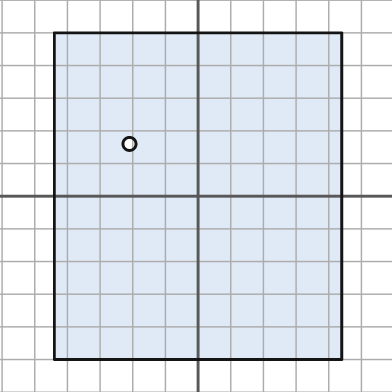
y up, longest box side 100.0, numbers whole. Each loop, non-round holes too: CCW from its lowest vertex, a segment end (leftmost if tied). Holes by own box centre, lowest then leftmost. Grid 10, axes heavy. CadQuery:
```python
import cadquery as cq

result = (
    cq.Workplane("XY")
    .moveTo(-44.0, -50.0)
    .lineTo(44.0, -50.0)
    .lineTo(44.0, 50.0)
    .lineTo(-44.0, 50.0)
    .close()
    .moveTo(-21.0, 16.0)
    .circle(2.0)
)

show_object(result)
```